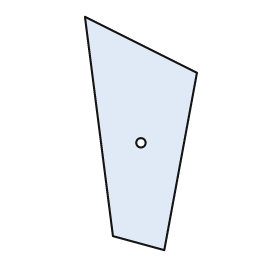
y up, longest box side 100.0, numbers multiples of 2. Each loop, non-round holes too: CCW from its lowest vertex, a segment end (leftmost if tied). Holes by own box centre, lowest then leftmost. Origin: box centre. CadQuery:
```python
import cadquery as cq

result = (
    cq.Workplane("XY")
    .moveTo(10.0, -50.0)
    .lineTo(24.0, 26.0)
    .lineTo(-24.0, 50.0)
    .lineTo(-12.0, -44.0)
    .close()
    .moveTo(0.0, -4.0)
    .circle(2.0)
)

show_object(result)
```